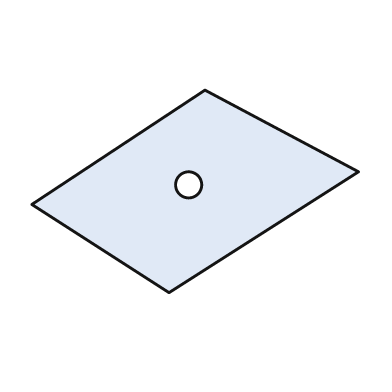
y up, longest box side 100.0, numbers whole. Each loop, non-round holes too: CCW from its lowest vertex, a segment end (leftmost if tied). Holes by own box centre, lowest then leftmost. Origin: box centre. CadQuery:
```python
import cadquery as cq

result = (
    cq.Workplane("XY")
    .moveTo(-8.0, -31.0)
    .lineTo(50.0, 6.0)
    .lineTo(3.0, 31.0)
    .lineTo(-50.0, -4.0)
    .close()
    .moveTo(-2.0, 2.0)
    .circle(4.0)
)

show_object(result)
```